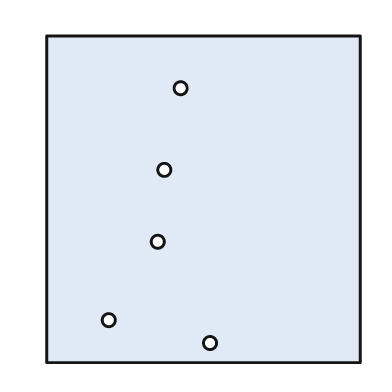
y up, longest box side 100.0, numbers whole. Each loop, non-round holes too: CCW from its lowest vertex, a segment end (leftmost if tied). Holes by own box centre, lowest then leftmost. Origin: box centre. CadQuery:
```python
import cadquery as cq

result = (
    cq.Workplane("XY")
    .moveTo(-48.0, -50.0)
    .lineTo(48.0, -50.0)
    .lineTo(48.0, 50.0)
    .lineTo(-48.0, 50.0)
    .close()
    .moveTo(2.0, -44.0)
    .circle(2.0)
    .moveTo(-29.0, -37.0)
    .circle(2.0)
    .moveTo(-14.0, -13.0)
    .circle(2.0)
    .moveTo(-12.0, 9.0)
    .circle(2.0)
    .moveTo(-7.0, 34.0)
    .circle(2.0)
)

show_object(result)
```